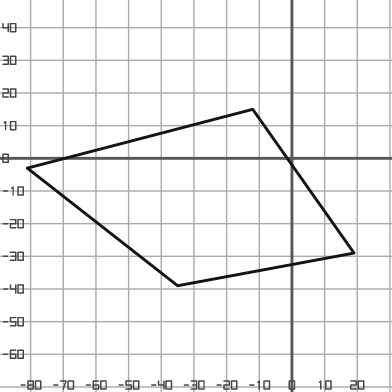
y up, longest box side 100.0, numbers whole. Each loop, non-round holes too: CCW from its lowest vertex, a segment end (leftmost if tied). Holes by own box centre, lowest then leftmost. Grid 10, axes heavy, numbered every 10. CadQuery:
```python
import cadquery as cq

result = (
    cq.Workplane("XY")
    .moveTo(-35.0, -39.0)
    .lineTo(19.0, -29.0)
    .lineTo(-12.0, 15.0)
    .lineTo(-81.0, -3.0)
    .close()
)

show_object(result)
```